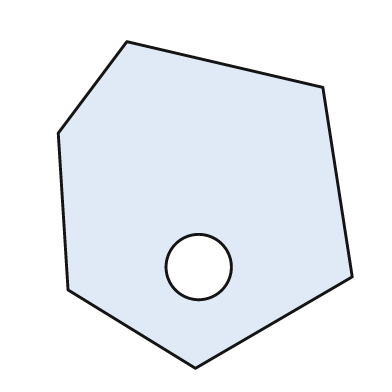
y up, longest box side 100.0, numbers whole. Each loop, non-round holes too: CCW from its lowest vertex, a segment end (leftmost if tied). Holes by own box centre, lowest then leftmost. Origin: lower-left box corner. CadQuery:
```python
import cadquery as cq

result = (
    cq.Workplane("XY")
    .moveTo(42.0, 0.0)
    .lineTo(90.0, 28.0)
    .lineTo(81.0, 86.0)
    .lineTo(21.0, 100.0)
    .lineTo(0.0, 72.0)
    .lineTo(3.0, 24.0)
    .close()
    .moveTo(43.0, 31.0)
    .circle(10.0)
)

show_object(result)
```